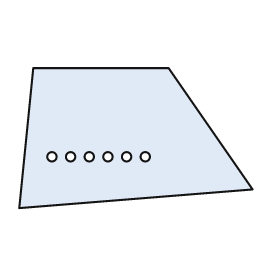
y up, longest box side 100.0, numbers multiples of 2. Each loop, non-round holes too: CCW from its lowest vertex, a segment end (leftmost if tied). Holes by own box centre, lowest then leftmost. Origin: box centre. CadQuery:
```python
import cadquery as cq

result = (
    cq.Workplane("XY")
    .moveTo(-50.0, -30.0)
    .lineTo(50.0, -22.0)
    .lineTo(14.0, 30.0)
    .lineTo(-44.0, 30.0)
    .close()
    .moveTo(-36.0, -8.0)
    .circle(2.0)
    .moveTo(-28.0, -8.0)
    .circle(2.0)
    .moveTo(-20.0, -8.0)
    .circle(2.0)
    .moveTo(-12.0, -8.0)
    .circle(2.0)
    .moveTo(-4.0, -8.0)
    .circle(2.0)
    .moveTo(4.0, -8.0)
    .circle(2.0)
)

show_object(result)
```